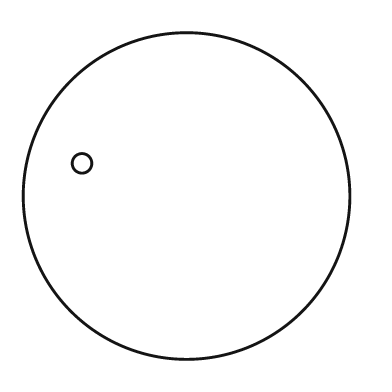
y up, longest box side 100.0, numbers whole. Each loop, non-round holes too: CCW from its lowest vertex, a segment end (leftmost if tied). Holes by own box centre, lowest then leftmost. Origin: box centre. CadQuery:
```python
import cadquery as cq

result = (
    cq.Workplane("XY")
    .moveTo(0.0, 0.0)
    .circle(50.0)
    .moveTo(-32.0, 10.0)
    .circle(3.0)
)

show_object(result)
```